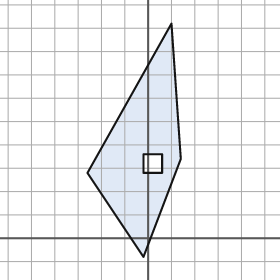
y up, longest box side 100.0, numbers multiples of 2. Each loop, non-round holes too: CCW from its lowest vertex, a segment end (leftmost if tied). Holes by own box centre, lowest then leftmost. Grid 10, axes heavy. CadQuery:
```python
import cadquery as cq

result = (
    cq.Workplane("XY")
    .moveTo(-2.0, -8.0)
    .lineTo(14.0, 34.0)
    .lineTo(10.0, 92.0)
    .lineTo(-26.0, 28.0)
    .close()
    .moveTo(-2.0, 28.0)
    .lineTo(6.0, 28.0)
    .lineTo(6.0, 36.0)
    .lineTo(-2.0, 36.0)
    .close()
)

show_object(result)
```